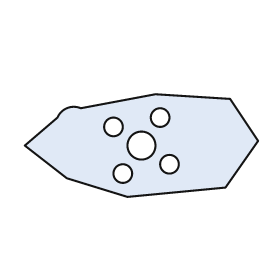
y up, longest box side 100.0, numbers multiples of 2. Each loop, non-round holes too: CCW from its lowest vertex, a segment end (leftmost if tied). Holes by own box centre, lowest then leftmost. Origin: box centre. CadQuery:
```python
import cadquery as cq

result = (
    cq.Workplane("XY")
    .moveTo(-6.0, -22.0)
    .lineTo(36.0, -18.0)
    .lineTo(50.0, 2.0)
    .lineTo(38.0, 20.0)
    .lineTo(6.0, 22.0)
    .lineTo(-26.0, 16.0)
    .threePointArc((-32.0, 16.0), (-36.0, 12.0))
    .lineTo(-50.0, 0.0)
    .lineTo(-32.0, -14.0)
    .close()
    .moveTo(-8.0, -12.0)
    .circle(4.0)
    .moveTo(12.0, -8.0)
    .circle(4.0)
    .moveTo(0.0, 0.0)
    .circle(6.0)
    .moveTo(-12.0, 8.0)
    .circle(4.0)
    .moveTo(8.0, 12.0)
    .circle(4.0)
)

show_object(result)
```